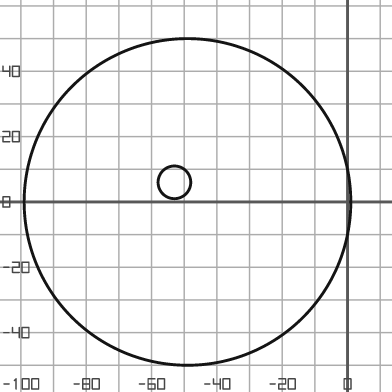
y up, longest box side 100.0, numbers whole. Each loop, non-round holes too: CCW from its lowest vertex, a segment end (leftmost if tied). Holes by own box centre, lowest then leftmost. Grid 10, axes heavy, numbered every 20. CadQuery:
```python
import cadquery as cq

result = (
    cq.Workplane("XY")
    .moveTo(-49.0, 0.0)
    .circle(50.0)
    .moveTo(-53.0, 6.0)
    .circle(5.0)
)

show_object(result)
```